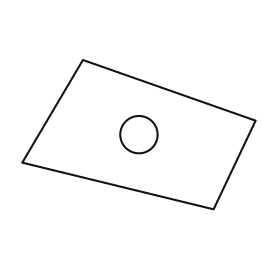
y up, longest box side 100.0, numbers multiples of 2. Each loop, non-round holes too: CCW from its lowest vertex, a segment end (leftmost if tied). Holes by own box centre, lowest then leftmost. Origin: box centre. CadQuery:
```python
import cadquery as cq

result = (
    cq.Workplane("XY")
    .moveTo(32.0, -32.0)
    .lineTo(50.0, 6.0)
    .lineTo(-24.0, 32.0)
    .lineTo(-50.0, -12.0)
    .close()
    .moveTo(0.0, 0.0)
    .circle(8.0)
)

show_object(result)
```